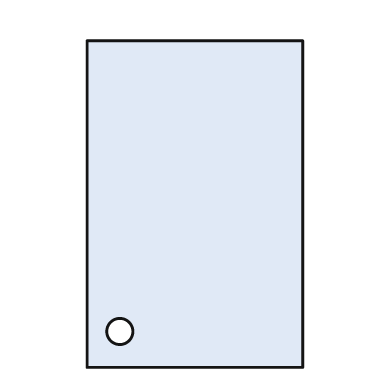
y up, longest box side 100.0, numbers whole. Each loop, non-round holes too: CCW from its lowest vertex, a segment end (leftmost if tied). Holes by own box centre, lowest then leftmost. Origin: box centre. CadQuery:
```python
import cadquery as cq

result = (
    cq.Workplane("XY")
    .moveTo(-33.0, -50.0)
    .lineTo(33.0, -50.0)
    .lineTo(33.0, 50.0)
    .lineTo(-33.0, 50.0)
    .close()
    .moveTo(-23.0, -39.0)
    .circle(4.0)
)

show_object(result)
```